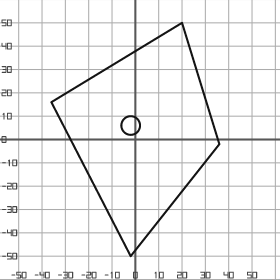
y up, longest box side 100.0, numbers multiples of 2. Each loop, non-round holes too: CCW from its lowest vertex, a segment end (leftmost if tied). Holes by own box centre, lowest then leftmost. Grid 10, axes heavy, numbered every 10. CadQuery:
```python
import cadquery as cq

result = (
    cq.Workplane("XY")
    .moveTo(-2.0, -50.0)
    .lineTo(36.0, -2.0)
    .lineTo(20.0, 50.0)
    .lineTo(-36.0, 16.0)
    .close()
    .moveTo(-2.0, 6.0)
    .circle(4.0)
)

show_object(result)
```